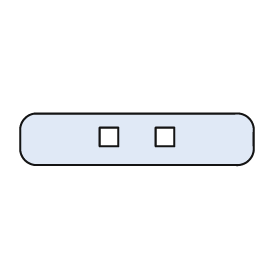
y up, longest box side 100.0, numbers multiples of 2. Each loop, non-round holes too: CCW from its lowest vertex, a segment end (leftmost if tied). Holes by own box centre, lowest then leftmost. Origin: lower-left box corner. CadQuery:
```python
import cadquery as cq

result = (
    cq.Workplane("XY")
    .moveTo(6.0, 0.0)
    .lineTo(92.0, 0.0)
    .threePointArc((98.0, 2.0), (100.0, 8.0))
    .lineTo(100.0, 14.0)
    .threePointArc((98.0, 20.0), (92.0, 22.0))
    .lineTo(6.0, 22.0)
    .threePointArc((2.0, 20.0), (0.0, 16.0))
    .lineTo(0.0, 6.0)
    .threePointArc((2.0, 2.0), (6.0, 0.0))
    .close()
    .moveTo(34.0, 8.0)
    .lineTo(42.0, 8.0)
    .lineTo(42.0, 16.0)
    .lineTo(34.0, 16.0)
    .close()
    .moveTo(58.0, 8.0)
    .lineTo(66.0, 8.0)
    .lineTo(66.0, 16.0)
    .lineTo(58.0, 16.0)
    .close()
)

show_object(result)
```